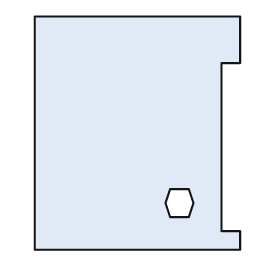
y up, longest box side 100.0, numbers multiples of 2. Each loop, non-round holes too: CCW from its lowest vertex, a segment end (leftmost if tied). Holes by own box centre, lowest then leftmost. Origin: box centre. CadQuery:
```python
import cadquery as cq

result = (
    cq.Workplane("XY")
    .moveTo(-44.0, -50.0)
    .lineTo(44.0, -50.0)
    .lineTo(44.0, -42.0)
    .lineTo(36.0, -42.0)
    .lineTo(36.0, 30.0)
    .lineTo(44.0, 30.0)
    .lineTo(44.0, 50.0)
    .lineTo(-44.0, 50.0)
    .close()
    .moveTo(14.0, -36.0)
    .lineTo(22.0, -36.0)
    .lineTo(24.0, -30.0)
    .lineTo(22.0, -24.0)
    .lineTo(14.0, -24.0)
    .lineTo(12.0, -30.0)
    .close()
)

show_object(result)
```